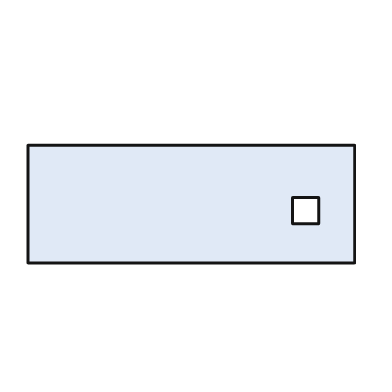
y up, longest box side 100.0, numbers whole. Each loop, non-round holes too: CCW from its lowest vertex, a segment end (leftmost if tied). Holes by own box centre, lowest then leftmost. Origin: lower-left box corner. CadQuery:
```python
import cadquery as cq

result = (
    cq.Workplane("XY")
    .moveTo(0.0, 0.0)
    .lineTo(100.0, 0.0)
    .lineTo(100.0, 36.0)
    .lineTo(0.0, 36.0)
    .close()
    .moveTo(81.0, 12.0)
    .lineTo(89.0, 12.0)
    .lineTo(89.0, 20.0)
    .lineTo(81.0, 20.0)
    .close()
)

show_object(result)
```